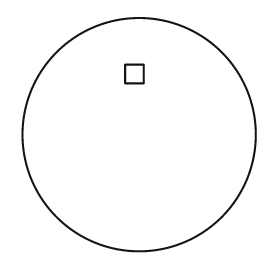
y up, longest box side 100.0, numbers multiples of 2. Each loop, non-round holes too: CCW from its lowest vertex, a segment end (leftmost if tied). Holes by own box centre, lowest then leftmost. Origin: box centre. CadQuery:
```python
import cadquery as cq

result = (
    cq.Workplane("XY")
    .moveTo(0.0, 0.0)
    .circle(50.0)
    .moveTo(-6.0, 22.0)
    .lineTo(2.0, 22.0)
    .lineTo(2.0, 30.0)
    .lineTo(-6.0, 30.0)
    .close()
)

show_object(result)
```